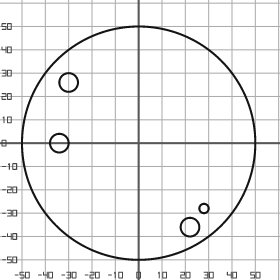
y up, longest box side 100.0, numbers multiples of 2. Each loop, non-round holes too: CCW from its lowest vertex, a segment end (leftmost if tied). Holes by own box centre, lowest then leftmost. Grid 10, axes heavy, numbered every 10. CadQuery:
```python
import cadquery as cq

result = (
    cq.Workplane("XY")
    .moveTo(0.0, 0.0)
    .circle(50.0)
    .moveTo(22.0, -36.0)
    .circle(4.0)
    .moveTo(28.0, -28.0)
    .circle(2.0)
    .moveTo(-34.0, 0.0)
    .circle(4.0)
    .moveTo(-30.0, 26.0)
    .circle(4.0)
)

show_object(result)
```